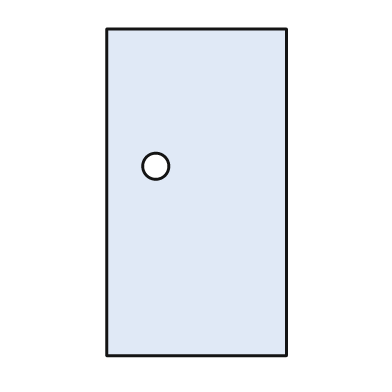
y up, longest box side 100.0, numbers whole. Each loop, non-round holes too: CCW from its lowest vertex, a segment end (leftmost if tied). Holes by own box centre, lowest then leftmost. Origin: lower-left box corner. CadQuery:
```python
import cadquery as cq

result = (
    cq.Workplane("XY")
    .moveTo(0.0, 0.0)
    .lineTo(55.0, 0.0)
    .lineTo(55.0, 100.0)
    .lineTo(0.0, 100.0)
    .close()
    .moveTo(15.0, 58.0)
    .circle(4.0)
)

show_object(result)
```